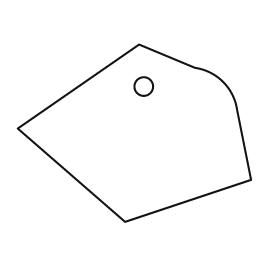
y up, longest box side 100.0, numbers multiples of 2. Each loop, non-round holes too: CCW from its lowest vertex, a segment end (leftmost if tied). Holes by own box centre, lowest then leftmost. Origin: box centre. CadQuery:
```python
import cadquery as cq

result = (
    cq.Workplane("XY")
    .moveTo(-4.0, -38.0)
    .lineTo(50.0, -20.0)
    .lineTo(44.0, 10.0)
    .threePointArc((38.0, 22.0), (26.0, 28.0))
    .lineTo(2.0, 38.0)
    .lineTo(-50.0, 2.0)
    .close()
    .moveTo(4.0, 20.0)
    .circle(4.0)
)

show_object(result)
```